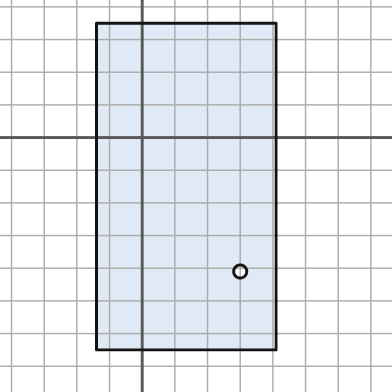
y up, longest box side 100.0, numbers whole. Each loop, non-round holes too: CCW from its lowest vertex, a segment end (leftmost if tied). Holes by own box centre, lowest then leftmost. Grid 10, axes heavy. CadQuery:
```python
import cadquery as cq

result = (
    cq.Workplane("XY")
    .moveTo(-14.0, -65.0)
    .lineTo(41.0, -65.0)
    .lineTo(41.0, 35.0)
    .lineTo(-14.0, 35.0)
    .close()
    .moveTo(30.0, -41.0)
    .circle(2.0)
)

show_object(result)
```